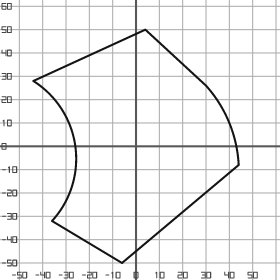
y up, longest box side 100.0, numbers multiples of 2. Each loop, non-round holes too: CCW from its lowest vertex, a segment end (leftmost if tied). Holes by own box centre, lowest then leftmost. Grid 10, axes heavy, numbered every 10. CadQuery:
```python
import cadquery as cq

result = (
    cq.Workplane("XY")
    .moveTo(-6.0, -50.0)
    .lineTo(44.0, -8.0)
    .threePointArc((40.0, 10.0), (30.0, 26.0))
    .lineTo(4.0, 50.0)
    .lineTo(-44.0, 28.0)
    .threePointArc((-26.0, 0.0), (-36.0, -32.0))
    .close()
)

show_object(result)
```